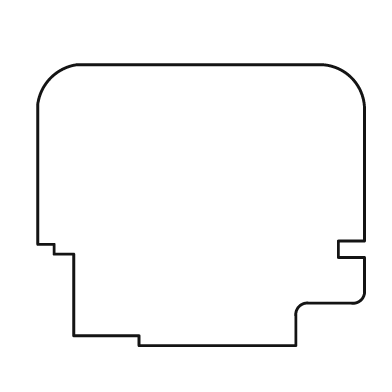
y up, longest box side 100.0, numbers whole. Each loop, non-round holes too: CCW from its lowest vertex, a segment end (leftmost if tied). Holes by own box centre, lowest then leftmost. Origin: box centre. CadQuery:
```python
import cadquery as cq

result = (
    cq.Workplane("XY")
    .moveTo(-19.0, -43.0)
    .lineTo(29.0, -43.0)
    .lineTo(29.0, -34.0)
    .threePointArc((30.0, -31.0), (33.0, -30.0))
    .lineTo(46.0, -30.0)
    .threePointArc((49.0, -29.0), (50.0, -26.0))
    .lineTo(50.0, -16.0)
    .lineTo(42.0, -16.0)
    .lineTo(42.0, -11.0)
    .lineTo(50.0, -11.0)
    .lineTo(50.0, 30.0)
    .threePointArc((46.0, 39.0), (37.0, 43.0))
    .lineTo(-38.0, 43.0)
    .threePointArc((-46.0, 39.0), (-50.0, 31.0))
    .lineTo(-50.0, -12.0)
    .lineTo(-45.0, -12.0)
    .lineTo(-45.0, -15.0)
    .lineTo(-39.0, -15.0)
    .lineTo(-39.0, -40.0)
    .lineTo(-19.0, -40.0)
    .close()
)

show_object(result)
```